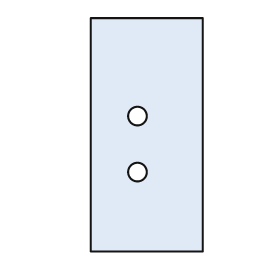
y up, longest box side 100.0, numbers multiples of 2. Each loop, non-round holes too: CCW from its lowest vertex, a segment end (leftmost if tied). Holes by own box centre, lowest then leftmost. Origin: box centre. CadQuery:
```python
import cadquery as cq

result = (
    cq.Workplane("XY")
    .moveTo(-24.0, -50.0)
    .lineTo(24.0, -50.0)
    .lineTo(24.0, 50.0)
    .lineTo(-24.0, 50.0)
    .close()
    .moveTo(-4.0, -16.0)
    .circle(4.0)
    .moveTo(-4.0, 8.0)
    .circle(4.0)
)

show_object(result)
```